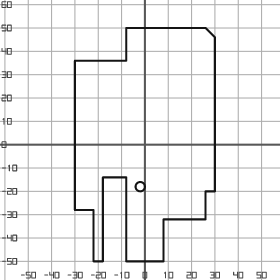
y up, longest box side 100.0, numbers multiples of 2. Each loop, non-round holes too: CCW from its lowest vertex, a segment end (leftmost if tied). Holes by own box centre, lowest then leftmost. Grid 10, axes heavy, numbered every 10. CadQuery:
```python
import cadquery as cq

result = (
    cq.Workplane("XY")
    .moveTo(-22.0, -50.0)
    .lineTo(-18.0, -50.0)
    .lineTo(-18.0, -14.0)
    .lineTo(-8.0, -14.0)
    .lineTo(-8.0, -50.0)
    .lineTo(8.0, -50.0)
    .lineTo(8.0, -32.0)
    .lineTo(26.0, -32.0)
    .lineTo(26.0, -20.0)
    .lineTo(30.0, -20.0)
    .lineTo(30.0, 46.0)
    .lineTo(26.0, 50.0)
    .lineTo(-8.0, 50.0)
    .lineTo(-8.0, 36.0)
    .lineTo(-30.0, 36.0)
    .lineTo(-30.0, -28.0)
    .lineTo(-22.0, -28.0)
    .close()
    .moveTo(-2.0, -18.0)
    .circle(2.0)
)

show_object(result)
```